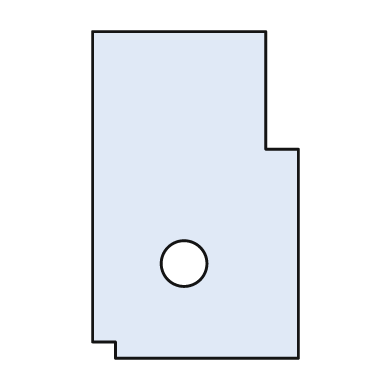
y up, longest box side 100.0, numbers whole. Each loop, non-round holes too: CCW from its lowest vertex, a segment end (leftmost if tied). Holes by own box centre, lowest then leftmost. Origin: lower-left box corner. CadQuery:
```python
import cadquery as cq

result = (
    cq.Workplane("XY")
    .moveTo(7.0, 0.0)
    .lineTo(63.0, 0.0)
    .lineTo(63.0, 64.0)
    .lineTo(53.0, 64.0)
    .lineTo(53.0, 100.0)
    .lineTo(0.0, 100.0)
    .lineTo(0.0, 5.0)
    .lineTo(7.0, 5.0)
    .close()
    .moveTo(28.0, 29.0)
    .circle(7.0)
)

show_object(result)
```